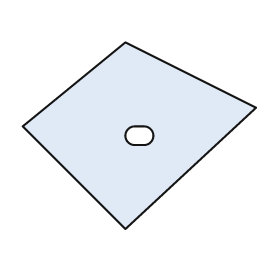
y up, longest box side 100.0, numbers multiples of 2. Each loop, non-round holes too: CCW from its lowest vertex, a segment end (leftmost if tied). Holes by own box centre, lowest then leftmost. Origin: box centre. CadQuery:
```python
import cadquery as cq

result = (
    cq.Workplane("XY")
    .moveTo(-6.0, -40.0)
    .lineTo(50.0, 12.0)
    .lineTo(-6.0, 40.0)
    .lineTo(-50.0, 4.0)
    .close()
    .moveTo(-2.0, -4.0)
    .lineTo(2.0, -4.0)
    .threePointArc((6.0, 0.0), (2.0, 4.0))
    .lineTo(-2.0, 4.0)
    .threePointArc((-6.0, 0.0), (-2.0, -4.0))
    .close()
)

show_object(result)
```